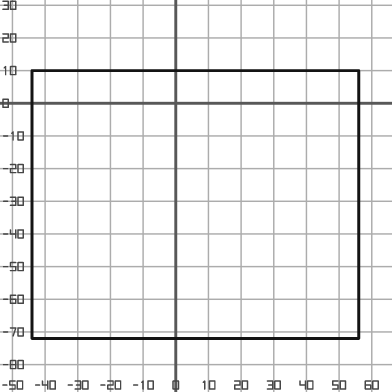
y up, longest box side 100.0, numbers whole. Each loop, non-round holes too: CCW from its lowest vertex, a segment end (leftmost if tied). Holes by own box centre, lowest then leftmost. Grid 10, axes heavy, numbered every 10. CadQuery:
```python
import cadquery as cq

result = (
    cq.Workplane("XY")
    .moveTo(-44.0, -72.0)
    .lineTo(56.0, -72.0)
    .lineTo(56.0, 10.0)
    .lineTo(-44.0, 10.0)
    .close()
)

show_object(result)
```